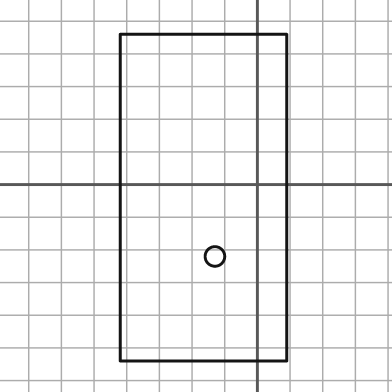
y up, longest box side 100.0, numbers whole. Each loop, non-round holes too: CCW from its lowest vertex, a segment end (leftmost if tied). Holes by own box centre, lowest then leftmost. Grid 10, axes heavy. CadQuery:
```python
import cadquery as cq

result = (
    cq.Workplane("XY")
    .moveTo(-42.0, -54.0)
    .lineTo(9.0, -54.0)
    .lineTo(9.0, 46.0)
    .lineTo(-42.0, 46.0)
    .close()
    .moveTo(-13.0, -22.0)
    .circle(3.0)
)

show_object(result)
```